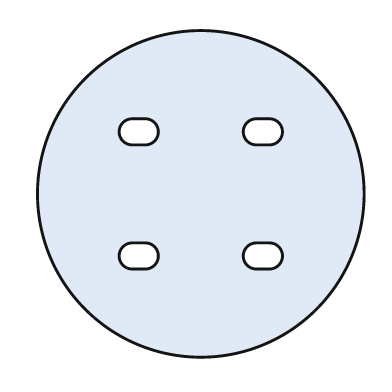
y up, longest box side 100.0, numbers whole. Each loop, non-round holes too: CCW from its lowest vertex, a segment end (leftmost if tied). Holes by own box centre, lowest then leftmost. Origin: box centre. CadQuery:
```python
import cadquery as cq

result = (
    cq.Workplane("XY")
    .moveTo(0.0, 0.0)
    .circle(50.0)
    .moveTo(-21.0, -23.0)
    .lineTo(-17.0, -23.0)
    .threePointArc((-13.0, -19.0), (-17.0, -15.0))
    .lineTo(-21.0, -15.0)
    .threePointArc((-25.0, -19.0), (-21.0, -23.0))
    .close()
    .moveTo(17.0, -23.0)
    .lineTo(21.0, -23.0)
    .threePointArc((25.0, -19.0), (21.0, -15.0))
    .lineTo(17.0, -15.0)
    .threePointArc((13.0, -19.0), (17.0, -23.0))
    .close()
    .moveTo(-21.0, 15.0)
    .lineTo(-17.0, 15.0)
    .threePointArc((-13.0, 19.0), (-17.0, 23.0))
    .lineTo(-21.0, 23.0)
    .threePointArc((-25.0, 19.0), (-21.0, 15.0))
    .close()
    .moveTo(17.0, 15.0)
    .lineTo(21.0, 15.0)
    .threePointArc((25.0, 19.0), (21.0, 23.0))
    .lineTo(17.0, 23.0)
    .threePointArc((13.0, 19.0), (17.0, 15.0))
    .close()
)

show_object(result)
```